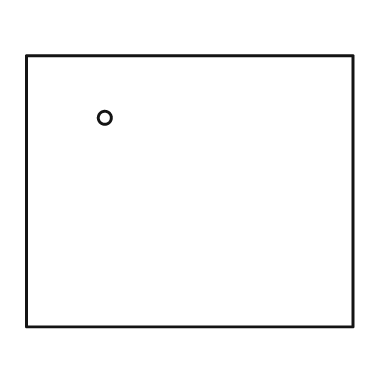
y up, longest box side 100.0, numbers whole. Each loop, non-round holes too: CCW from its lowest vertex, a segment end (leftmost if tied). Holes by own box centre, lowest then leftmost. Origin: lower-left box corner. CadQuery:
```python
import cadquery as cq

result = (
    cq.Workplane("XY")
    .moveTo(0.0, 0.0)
    .lineTo(100.0, 0.0)
    .lineTo(100.0, 83.0)
    .lineTo(0.0, 83.0)
    .close()
    .moveTo(24.0, 64.0)
    .circle(2.0)
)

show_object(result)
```